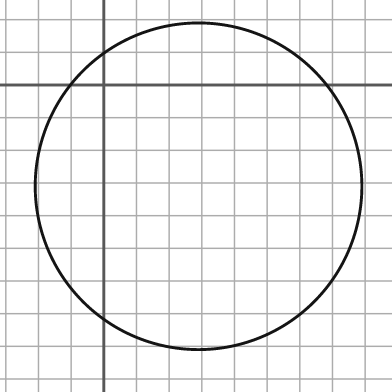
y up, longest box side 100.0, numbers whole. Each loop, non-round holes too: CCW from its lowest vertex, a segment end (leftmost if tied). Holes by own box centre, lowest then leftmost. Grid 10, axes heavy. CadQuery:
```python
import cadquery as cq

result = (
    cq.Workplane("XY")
    .moveTo(29.0, -31.0)
    .circle(50.0)
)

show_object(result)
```